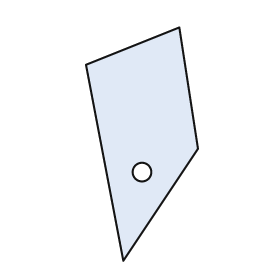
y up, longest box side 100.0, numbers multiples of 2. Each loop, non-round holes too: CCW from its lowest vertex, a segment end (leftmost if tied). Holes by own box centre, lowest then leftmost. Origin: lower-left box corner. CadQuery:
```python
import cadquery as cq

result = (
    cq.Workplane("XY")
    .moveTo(16.0, 0.0)
    .lineTo(48.0, 48.0)
    .lineTo(40.0, 100.0)
    .lineTo(0.0, 84.0)
    .close()
    .moveTo(24.0, 38.0)
    .circle(4.0)
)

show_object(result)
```